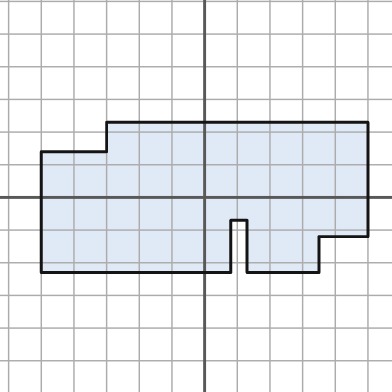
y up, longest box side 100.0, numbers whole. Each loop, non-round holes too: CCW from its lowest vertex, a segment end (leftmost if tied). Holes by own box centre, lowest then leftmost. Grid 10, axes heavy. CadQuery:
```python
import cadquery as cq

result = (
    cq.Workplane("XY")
    .moveTo(-50.0, -23.0)
    .lineTo(8.0, -23.0)
    .lineTo(8.0, -7.0)
    .lineTo(13.0, -7.0)
    .lineTo(13.0, -23.0)
    .lineTo(35.0, -23.0)
    .lineTo(35.0, -12.0)
    .lineTo(50.0, -12.0)
    .lineTo(50.0, 23.0)
    .lineTo(-30.0, 23.0)
    .lineTo(-30.0, 14.0)
    .lineTo(-50.0, 14.0)
    .close()
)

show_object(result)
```